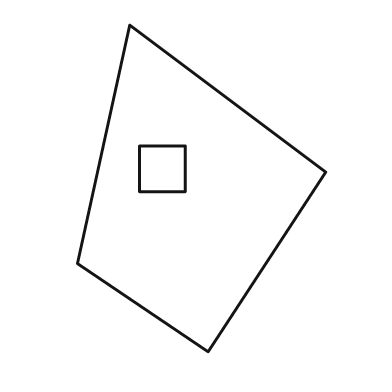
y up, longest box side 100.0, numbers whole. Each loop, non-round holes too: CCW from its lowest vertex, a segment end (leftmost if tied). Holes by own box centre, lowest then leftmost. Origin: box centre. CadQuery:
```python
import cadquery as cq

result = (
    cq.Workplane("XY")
    .moveTo(2.0, -50.0)
    .lineTo(38.0, 5.0)
    .lineTo(-22.0, 50.0)
    .lineTo(-38.0, -23.0)
    .close()
    .moveTo(-19.0, -1.0)
    .lineTo(-5.0, -1.0)
    .lineTo(-5.0, 13.0)
    .lineTo(-19.0, 13.0)
    .close()
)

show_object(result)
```